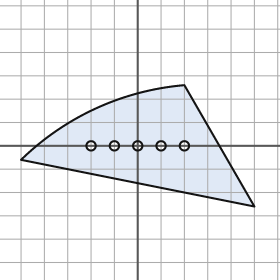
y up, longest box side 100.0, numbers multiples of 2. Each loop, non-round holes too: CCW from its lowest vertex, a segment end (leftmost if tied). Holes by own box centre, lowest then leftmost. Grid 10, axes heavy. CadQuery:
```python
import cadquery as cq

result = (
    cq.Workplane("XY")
    .moveTo(50.0, -26.0)
    .lineTo(20.0, 26.0)
    .threePointArc((-18.0, 16.0), (-50.0, -6.0))
    .close()
    .moveTo(-20.0, 0.0)
    .circle(2.0)
    .moveTo(-10.0, 0.0)
    .circle(2.0)
    .moveTo(0.0, 0.0)
    .circle(2.0)
    .moveTo(10.0, 0.0)
    .circle(2.0)
    .moveTo(20.0, 0.0)
    .circle(2.0)
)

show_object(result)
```